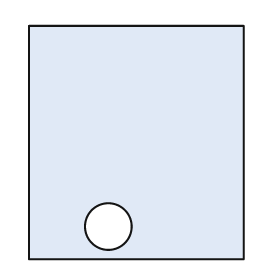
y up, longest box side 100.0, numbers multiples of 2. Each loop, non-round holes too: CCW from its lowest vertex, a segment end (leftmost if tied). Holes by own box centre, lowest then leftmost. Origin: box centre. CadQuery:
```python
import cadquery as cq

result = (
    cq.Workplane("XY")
    .moveTo(-46.0, -50.0)
    .lineTo(46.0, -50.0)
    .lineTo(46.0, 50.0)
    .lineTo(-46.0, 50.0)
    .close()
    .moveTo(-12.0, -36.0)
    .circle(10.0)
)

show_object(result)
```